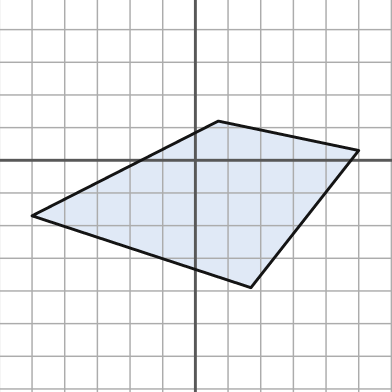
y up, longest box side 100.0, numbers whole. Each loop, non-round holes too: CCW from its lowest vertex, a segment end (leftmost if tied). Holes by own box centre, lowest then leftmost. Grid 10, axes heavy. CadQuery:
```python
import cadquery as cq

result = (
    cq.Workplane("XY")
    .moveTo(17.0, -39.0)
    .lineTo(50.0, 3.0)
    .lineTo(7.0, 12.0)
    .lineTo(-50.0, -17.0)
    .close()
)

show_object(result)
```